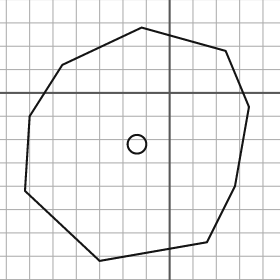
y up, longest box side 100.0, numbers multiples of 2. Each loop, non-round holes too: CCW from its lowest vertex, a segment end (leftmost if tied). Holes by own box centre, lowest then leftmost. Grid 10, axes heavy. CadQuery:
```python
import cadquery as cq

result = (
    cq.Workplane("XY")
    .moveTo(-30.0, -72.0)
    .lineTo(16.0, -64.0)
    .lineTo(28.0, -40.0)
    .lineTo(34.0, -6.0)
    .lineTo(24.0, 18.0)
    .lineTo(-12.0, 28.0)
    .lineTo(-46.0, 12.0)
    .lineTo(-60.0, -10.0)
    .lineTo(-62.0, -42.0)
    .close()
    .moveTo(-14.0, -22.0)
    .circle(4.0)
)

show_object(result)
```